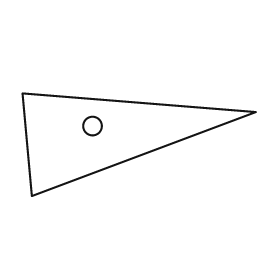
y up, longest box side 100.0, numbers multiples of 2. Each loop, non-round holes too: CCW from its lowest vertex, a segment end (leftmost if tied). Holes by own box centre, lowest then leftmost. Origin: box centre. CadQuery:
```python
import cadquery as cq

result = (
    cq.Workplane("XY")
    .moveTo(-46.0, -22.0)
    .lineTo(50.0, 14.0)
    .lineTo(-50.0, 22.0)
    .close()
    .moveTo(-20.0, 8.0)
    .circle(4.0)
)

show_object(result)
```